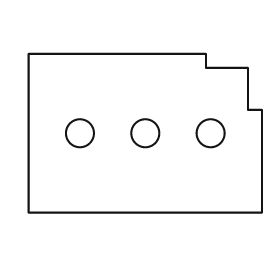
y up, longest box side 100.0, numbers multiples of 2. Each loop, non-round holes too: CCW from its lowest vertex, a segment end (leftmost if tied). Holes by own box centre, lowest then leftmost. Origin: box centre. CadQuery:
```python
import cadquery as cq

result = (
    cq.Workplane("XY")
    .moveTo(-50.0, -34.0)
    .lineTo(50.0, -34.0)
    .lineTo(50.0, 10.0)
    .lineTo(44.0, 10.0)
    .lineTo(44.0, 28.0)
    .lineTo(26.0, 28.0)
    .lineTo(26.0, 34.0)
    .lineTo(-50.0, 34.0)
    .close()
    .moveTo(-28.0, 0.0)
    .circle(6.0)
    .moveTo(0.0, 0.0)
    .circle(6.0)
    .moveTo(28.0, 0.0)
    .circle(6.0)
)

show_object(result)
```